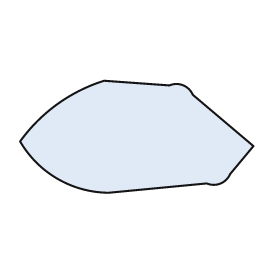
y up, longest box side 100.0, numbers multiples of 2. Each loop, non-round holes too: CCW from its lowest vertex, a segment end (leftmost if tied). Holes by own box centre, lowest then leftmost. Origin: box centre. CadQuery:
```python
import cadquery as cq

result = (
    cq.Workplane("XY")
    .moveTo(-12.0, -24.0)
    .lineTo(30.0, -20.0)
    .threePointArc((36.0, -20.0), (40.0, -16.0))
    .lineTo(50.0, -4.0)
    .lineTo(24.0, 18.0)
    .threePointArc((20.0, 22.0), (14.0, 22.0))
    .lineTo(-14.0, 24.0)
    .threePointArc((-34.0, 14.0), (-50.0, -2.0))
    .threePointArc((-34.0, -18.0), (-12.0, -24.0))
    .close()
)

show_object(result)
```